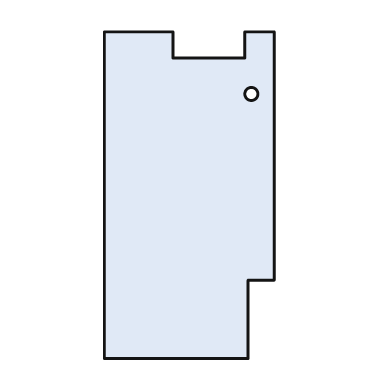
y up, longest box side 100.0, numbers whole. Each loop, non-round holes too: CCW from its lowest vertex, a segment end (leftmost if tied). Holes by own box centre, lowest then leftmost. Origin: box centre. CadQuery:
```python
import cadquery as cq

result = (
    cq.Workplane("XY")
    .moveTo(-26.0, -50.0)
    .lineTo(18.0, -50.0)
    .lineTo(18.0, -26.0)
    .lineTo(26.0, -26.0)
    .lineTo(26.0, 50.0)
    .lineTo(17.0, 50.0)
    .lineTo(17.0, 42.0)
    .lineTo(-5.0, 42.0)
    .lineTo(-5.0, 50.0)
    .lineTo(-26.0, 50.0)
    .close()
    .moveTo(19.0, 31.0)
    .circle(2.0)
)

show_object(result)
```